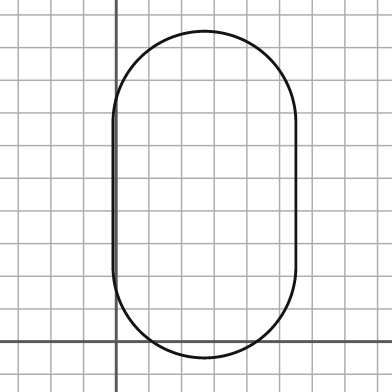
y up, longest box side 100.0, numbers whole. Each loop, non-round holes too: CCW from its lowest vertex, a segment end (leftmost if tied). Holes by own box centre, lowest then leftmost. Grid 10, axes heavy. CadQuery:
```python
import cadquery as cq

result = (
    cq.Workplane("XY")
    .moveTo(-1.0, 23.0)
    .threePointArc((27.0, -5.0), (55.0, 23.0))
    .lineTo(55.0, 67.0)
    .threePointArc((27.0, 95.0), (-1.0, 67.0))
    .close()
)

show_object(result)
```